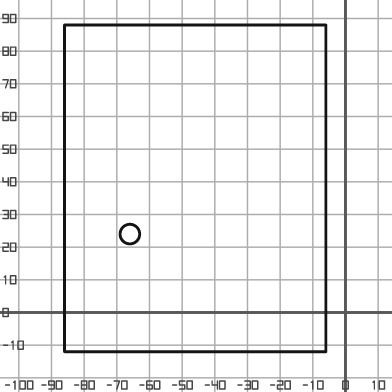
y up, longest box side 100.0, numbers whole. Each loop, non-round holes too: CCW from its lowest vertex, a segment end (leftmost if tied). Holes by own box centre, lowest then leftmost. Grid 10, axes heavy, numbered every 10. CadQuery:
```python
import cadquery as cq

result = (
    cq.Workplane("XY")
    .moveTo(-86.0, -12.0)
    .lineTo(-6.0, -12.0)
    .lineTo(-6.0, 88.0)
    .lineTo(-86.0, 88.0)
    .close()
    .moveTo(-66.0, 24.0)
    .circle(3.0)
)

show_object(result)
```